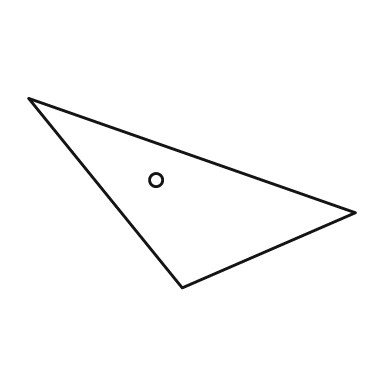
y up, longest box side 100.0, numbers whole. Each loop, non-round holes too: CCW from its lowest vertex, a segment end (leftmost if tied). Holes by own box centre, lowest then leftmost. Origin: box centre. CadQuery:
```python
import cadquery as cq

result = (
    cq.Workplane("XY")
    .moveTo(-3.0, -29.0)
    .lineTo(50.0, -6.0)
    .lineTo(-50.0, 29.0)
    .close()
    .moveTo(-11.0, 4.0)
    .circle(2.0)
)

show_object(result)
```